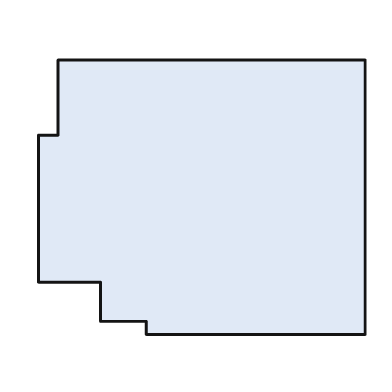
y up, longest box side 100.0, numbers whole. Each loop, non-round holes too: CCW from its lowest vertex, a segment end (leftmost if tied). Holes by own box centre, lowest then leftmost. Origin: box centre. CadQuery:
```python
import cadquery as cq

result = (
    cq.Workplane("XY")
    .moveTo(-17.0, -42.0)
    .lineTo(50.0, -42.0)
    .lineTo(50.0, 42.0)
    .lineTo(-44.0, 42.0)
    .lineTo(-44.0, 19.0)
    .lineTo(-50.0, 19.0)
    .lineTo(-50.0, -26.0)
    .lineTo(-31.0, -26.0)
    .lineTo(-31.0, -38.0)
    .lineTo(-17.0, -38.0)
    .close()
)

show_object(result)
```